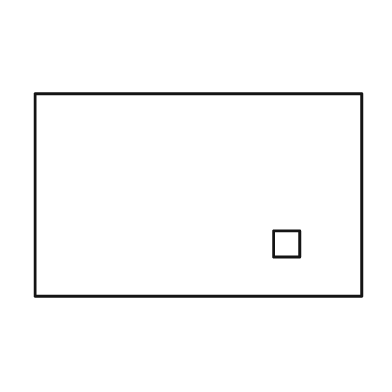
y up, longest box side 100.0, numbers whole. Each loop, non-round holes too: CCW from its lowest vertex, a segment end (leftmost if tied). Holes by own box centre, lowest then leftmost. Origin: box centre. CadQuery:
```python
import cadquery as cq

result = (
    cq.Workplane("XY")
    .moveTo(-50.0, -31.0)
    .lineTo(50.0, -31.0)
    .lineTo(50.0, 31.0)
    .lineTo(-50.0, 31.0)
    .close()
    .moveTo(23.0, -19.0)
    .lineTo(31.0, -19.0)
    .lineTo(31.0, -11.0)
    .lineTo(23.0, -11.0)
    .close()
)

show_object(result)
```